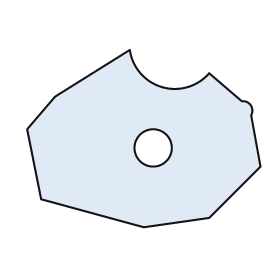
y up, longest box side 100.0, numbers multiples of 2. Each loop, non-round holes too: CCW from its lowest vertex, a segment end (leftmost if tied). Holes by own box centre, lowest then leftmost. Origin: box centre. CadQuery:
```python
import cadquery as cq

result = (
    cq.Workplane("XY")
    .moveTo(0.0, -38.0)
    .lineTo(28.0, -34.0)
    .lineTo(50.0, -12.0)
    .lineTo(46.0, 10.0)
    .threePointArc((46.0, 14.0), (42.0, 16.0))
    .lineTo(28.0, 28.0)
    .threePointArc((8.0, 22.0), (-6.0, 38.0))
    .lineTo(-38.0, 18.0)
    .lineTo(-50.0, 4.0)
    .lineTo(-44.0, -26.0)
    .close()
    .moveTo(4.0, -4.0)
    .circle(8.0)
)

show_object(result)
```